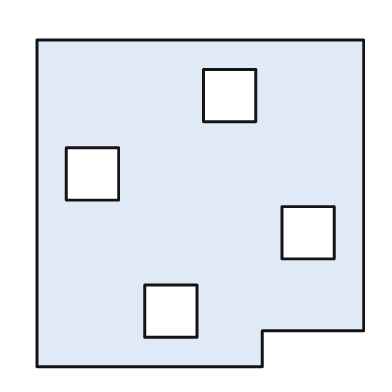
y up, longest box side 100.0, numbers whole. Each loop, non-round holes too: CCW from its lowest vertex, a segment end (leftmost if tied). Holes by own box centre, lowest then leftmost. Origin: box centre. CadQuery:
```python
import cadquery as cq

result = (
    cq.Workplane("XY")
    .moveTo(-50.0, -50.0)
    .lineTo(19.0, -50.0)
    .lineTo(19.0, -39.0)
    .lineTo(50.0, -39.0)
    .lineTo(50.0, 50.0)
    .lineTo(-50.0, 50.0)
    .close()
    .moveTo(-17.0, -41.0)
    .lineTo(-1.0, -41.0)
    .lineTo(-1.0, -25.0)
    .lineTo(-17.0, -25.0)
    .close()
    .moveTo(25.0, -17.0)
    .lineTo(41.0, -17.0)
    .lineTo(41.0, -1.0)
    .lineTo(25.0, -1.0)
    .close()
    .moveTo(-41.0, 1.0)
    .lineTo(-25.0, 1.0)
    .lineTo(-25.0, 17.0)
    .lineTo(-41.0, 17.0)
    .close()
    .moveTo(1.0, 25.0)
    .lineTo(17.0, 25.0)
    .lineTo(17.0, 41.0)
    .lineTo(1.0, 41.0)
    .close()
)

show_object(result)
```